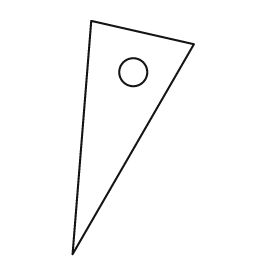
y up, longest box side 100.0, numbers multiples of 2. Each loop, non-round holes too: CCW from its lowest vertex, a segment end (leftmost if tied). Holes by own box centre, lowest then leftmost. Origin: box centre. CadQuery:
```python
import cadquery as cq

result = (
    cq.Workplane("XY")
    .moveTo(-26.0, -50.0)
    .lineTo(26.0, 40.0)
    .lineTo(-18.0, 50.0)
    .close()
    .moveTo(0.0, 28.0)
    .circle(6.0)
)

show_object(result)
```